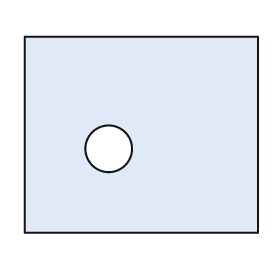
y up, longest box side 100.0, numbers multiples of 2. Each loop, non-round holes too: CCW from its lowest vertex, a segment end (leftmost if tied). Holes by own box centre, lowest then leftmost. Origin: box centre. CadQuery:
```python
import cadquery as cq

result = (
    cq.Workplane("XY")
    .moveTo(-50.0, -42.0)
    .lineTo(50.0, -42.0)
    .lineTo(50.0, 42.0)
    .lineTo(-50.0, 42.0)
    .close()
    .moveTo(-14.0, -6.0)
    .circle(10.0)
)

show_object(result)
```